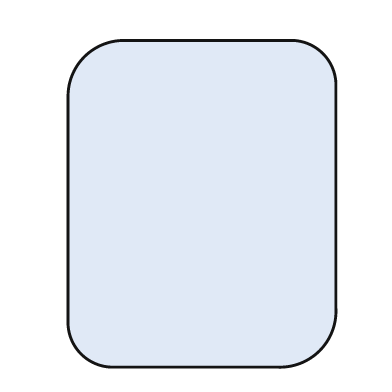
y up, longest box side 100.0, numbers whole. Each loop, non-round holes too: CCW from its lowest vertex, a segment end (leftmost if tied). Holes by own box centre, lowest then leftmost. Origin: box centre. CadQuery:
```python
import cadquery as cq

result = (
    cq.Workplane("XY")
    .moveTo(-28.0, -50.0)
    .lineTo(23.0, -50.0)
    .threePointArc((36.0, -45.0), (41.0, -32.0))
    .lineTo(41.0, 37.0)
    .threePointArc((37.0, 46.0), (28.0, 50.0))
    .lineTo(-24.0, 50.0)
    .threePointArc((-36.0, 45.0), (-41.0, 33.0))
    .lineTo(-41.0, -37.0)
    .threePointArc((-37.0, -46.0), (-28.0, -50.0))
    .close()
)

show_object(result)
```